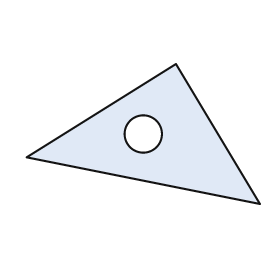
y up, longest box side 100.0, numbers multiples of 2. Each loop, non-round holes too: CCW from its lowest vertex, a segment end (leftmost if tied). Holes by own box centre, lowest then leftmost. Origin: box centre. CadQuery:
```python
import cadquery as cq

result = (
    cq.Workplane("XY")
    .moveTo(50.0, -30.0)
    .lineTo(14.0, 30.0)
    .lineTo(-50.0, -10.0)
    .close()
    .moveTo(0.0, 0.0)
    .circle(8.0)
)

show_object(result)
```